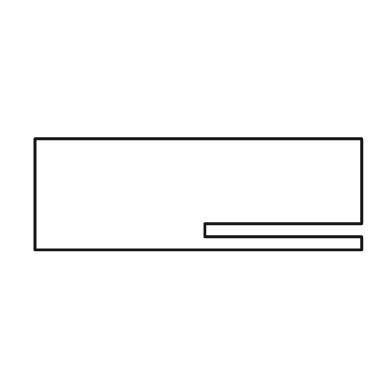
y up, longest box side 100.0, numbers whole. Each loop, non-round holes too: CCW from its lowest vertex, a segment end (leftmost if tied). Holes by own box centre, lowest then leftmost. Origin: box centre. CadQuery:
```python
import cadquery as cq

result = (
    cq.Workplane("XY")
    .moveTo(-50.0, -17.0)
    .lineTo(50.0, -17.0)
    .lineTo(50.0, -13.0)
    .lineTo(2.0, -13.0)
    .lineTo(2.0, -9.0)
    .lineTo(50.0, -9.0)
    .lineTo(50.0, 17.0)
    .lineTo(-50.0, 17.0)
    .close()
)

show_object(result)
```